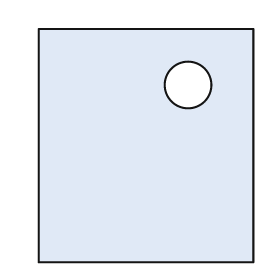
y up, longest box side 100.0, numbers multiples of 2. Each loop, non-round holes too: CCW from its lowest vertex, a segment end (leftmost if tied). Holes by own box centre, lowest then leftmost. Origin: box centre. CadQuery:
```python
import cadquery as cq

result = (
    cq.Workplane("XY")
    .moveTo(-46.0, -50.0)
    .lineTo(46.0, -50.0)
    .lineTo(46.0, 50.0)
    .lineTo(-46.0, 50.0)
    .close()
    .moveTo(18.0, 26.0)
    .circle(10.0)
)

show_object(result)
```